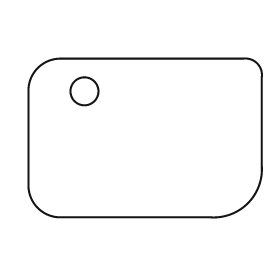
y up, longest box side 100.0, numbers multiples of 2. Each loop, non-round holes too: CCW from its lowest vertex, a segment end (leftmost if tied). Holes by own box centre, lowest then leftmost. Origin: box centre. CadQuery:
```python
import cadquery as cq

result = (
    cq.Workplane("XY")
    .moveTo(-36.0, -34.0)
    .lineTo(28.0, -34.0)
    .threePointArc((44.0, -28.0), (50.0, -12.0))
    .lineTo(50.0, 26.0)
    .threePointArc((48.0, 32.0), (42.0, 34.0))
    .lineTo(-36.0, 34.0)
    .threePointArc((-46.0, 30.0), (-50.0, 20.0))
    .lineTo(-50.0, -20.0)
    .threePointArc((-46.0, -30.0), (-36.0, -34.0))
    .close()
    .moveTo(-26.0, 20.0)
    .circle(6.0)
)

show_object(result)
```